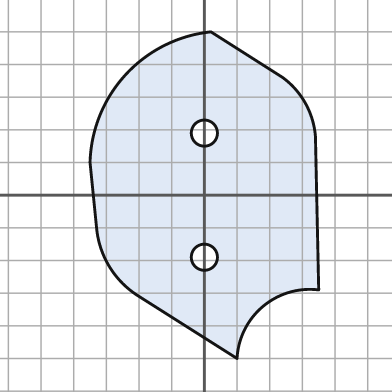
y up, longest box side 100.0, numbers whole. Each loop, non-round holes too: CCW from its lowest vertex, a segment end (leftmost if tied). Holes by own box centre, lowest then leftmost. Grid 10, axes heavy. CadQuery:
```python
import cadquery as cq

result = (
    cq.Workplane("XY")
    .moveTo(10.0, -50.0)
    .threePointArc((18.0, -34.0), (35.0, -29.0))
    .lineTo(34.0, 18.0)
    .threePointArc((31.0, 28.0), (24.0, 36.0))
    .lineTo(2.0, 50.0)
    .threePointArc((-24.0, 37.0), (-35.0, 10.0))
    .lineTo(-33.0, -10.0)
    .threePointArc((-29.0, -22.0), (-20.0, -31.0))
    .close()
    .moveTo(0.0, -19.0)
    .circle(4.0)
    .moveTo(0.0, 19.0)
    .circle(4.0)
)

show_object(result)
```